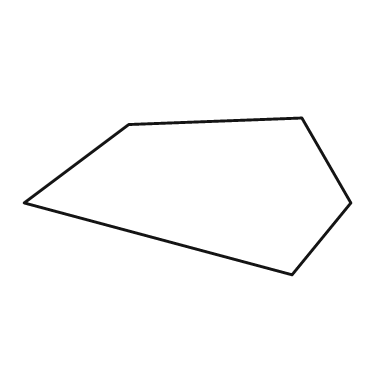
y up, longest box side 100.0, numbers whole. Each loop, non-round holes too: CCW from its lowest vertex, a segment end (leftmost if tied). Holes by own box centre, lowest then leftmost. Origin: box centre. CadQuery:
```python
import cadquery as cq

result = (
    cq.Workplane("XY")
    .moveTo(32.0, -24.0)
    .lineTo(50.0, -2.0)
    .lineTo(35.0, 24.0)
    .lineTo(-18.0, 22.0)
    .lineTo(-50.0, -2.0)
    .close()
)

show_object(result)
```